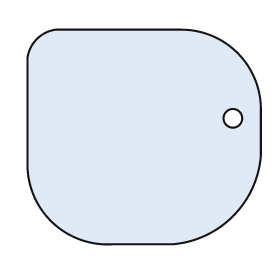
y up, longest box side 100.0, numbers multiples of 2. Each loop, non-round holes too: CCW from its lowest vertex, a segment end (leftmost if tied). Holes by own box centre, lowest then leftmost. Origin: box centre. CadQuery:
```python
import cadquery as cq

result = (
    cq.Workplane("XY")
    .moveTo(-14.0, -46.0)
    .lineTo(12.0, -46.0)
    .threePointArc((38.0, -34.0), (50.0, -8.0))
    .lineTo(50.0, 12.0)
    .threePointArc((40.0, 36.0), (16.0, 46.0))
    .lineTo(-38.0, 46.0)
    .threePointArc((-46.0, 42.0), (-50.0, 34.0))
    .lineTo(-50.0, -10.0)
    .threePointArc((-40.0, -36.0), (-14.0, -46.0))
    .close()
    .moveTo(38.0, 8.0)
    .circle(4.0)
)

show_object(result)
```